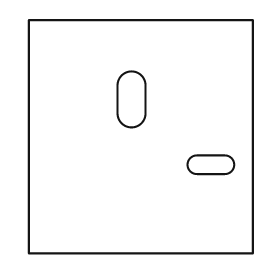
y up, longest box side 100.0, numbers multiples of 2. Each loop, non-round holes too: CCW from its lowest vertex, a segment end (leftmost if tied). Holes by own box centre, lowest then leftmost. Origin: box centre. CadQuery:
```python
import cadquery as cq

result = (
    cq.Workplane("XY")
    .moveTo(-48.0, -50.0)
    .lineTo(48.0, -50.0)
    .lineTo(48.0, 50.0)
    .lineTo(-48.0, 50.0)
    .close()
    .moveTo(24.0, -16.0)
    .lineTo(36.0, -16.0)
    .threePointArc((40.0, -12.0), (36.0, -8.0))
    .lineTo(24.0, -8.0)
    .threePointArc((20.0, -12.0), (24.0, -16.0))
    .close()
    .moveTo(-10.0, 10.0)
    .threePointArc((-4.0, 4.0), (2.0, 10.0))
    .lineTo(2.0, 22.0)
    .threePointArc((-4.0, 28.0), (-10.0, 22.0))
    .close()
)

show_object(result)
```